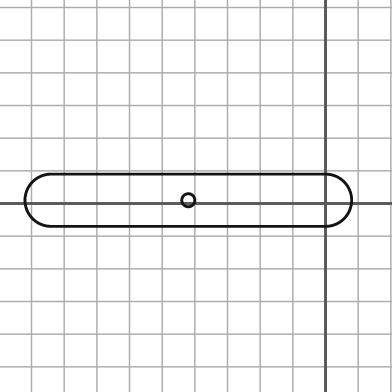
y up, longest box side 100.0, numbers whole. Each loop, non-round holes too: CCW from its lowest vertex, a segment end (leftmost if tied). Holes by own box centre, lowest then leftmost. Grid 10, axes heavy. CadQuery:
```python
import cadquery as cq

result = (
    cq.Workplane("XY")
    .moveTo(-84.0, -7.0)
    .lineTo(0.0, -7.0)
    .threePointArc((8.0, 1.0), (0.0, 9.0))
    .lineTo(-84.0, 9.0)
    .threePointArc((-92.0, 1.0), (-84.0, -7.0))
    .close()
    .moveTo(-42.0, 1.0)
    .circle(2.0)
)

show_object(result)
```